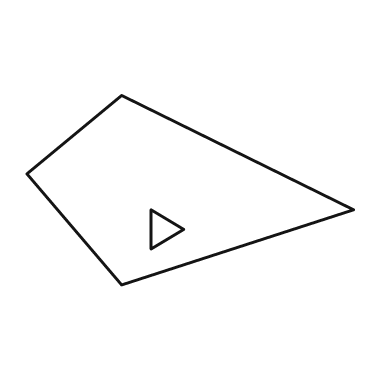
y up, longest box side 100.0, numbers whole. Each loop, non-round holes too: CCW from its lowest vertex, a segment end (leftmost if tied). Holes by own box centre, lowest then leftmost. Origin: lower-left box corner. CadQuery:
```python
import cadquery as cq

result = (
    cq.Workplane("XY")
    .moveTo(29.0, 0.0)
    .lineTo(100.0, 23.0)
    .lineTo(29.0, 58.0)
    .lineTo(0.0, 34.0)
    .close()
    .moveTo(38.0, 11.0)
    .lineTo(48.0, 17.0)
    .lineTo(38.0, 23.0)
    .close()
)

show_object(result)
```